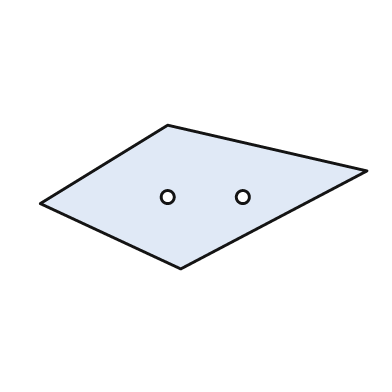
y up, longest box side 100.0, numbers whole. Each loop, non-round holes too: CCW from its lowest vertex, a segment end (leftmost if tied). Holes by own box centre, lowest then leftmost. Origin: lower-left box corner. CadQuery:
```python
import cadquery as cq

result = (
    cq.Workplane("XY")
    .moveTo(43.0, 0.0)
    .lineTo(100.0, 30.0)
    .lineTo(39.0, 44.0)
    .lineTo(0.0, 20.0)
    .close()
    .moveTo(39.0, 22.0)
    .circle(2.0)
    .moveTo(62.0, 22.0)
    .circle(2.0)
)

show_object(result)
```